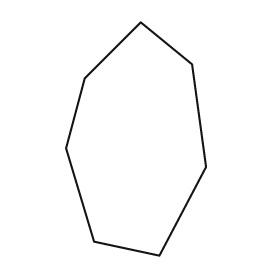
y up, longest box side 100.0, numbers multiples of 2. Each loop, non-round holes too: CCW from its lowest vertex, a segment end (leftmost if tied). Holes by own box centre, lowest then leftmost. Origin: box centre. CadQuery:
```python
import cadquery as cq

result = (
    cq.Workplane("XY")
    .moveTo(10.0, -50.0)
    .lineTo(30.0, -12.0)
    .lineTo(24.0, 32.0)
    .lineTo(2.0, 50.0)
    .lineTo(-22.0, 26.0)
    .lineTo(-30.0, -4.0)
    .lineTo(-18.0, -44.0)
    .close()
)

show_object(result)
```